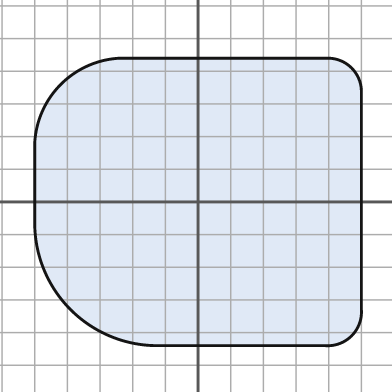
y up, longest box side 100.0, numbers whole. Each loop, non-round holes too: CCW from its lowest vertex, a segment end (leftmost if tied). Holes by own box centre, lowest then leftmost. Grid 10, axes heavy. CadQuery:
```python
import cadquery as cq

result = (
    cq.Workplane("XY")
    .moveTo(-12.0, -44.0)
    .lineTo(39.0, -44.0)
    .threePointArc((47.0, -41.0), (50.0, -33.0))
    .lineTo(50.0, 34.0)
    .threePointArc((47.0, 41.0), (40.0, 44.0))
    .lineTo(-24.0, 44.0)
    .threePointArc((-42.0, 36.0), (-50.0, 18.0))
    .lineTo(-50.0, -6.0)
    .threePointArc((-39.0, -33.0), (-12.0, -44.0))
    .close()
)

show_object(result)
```